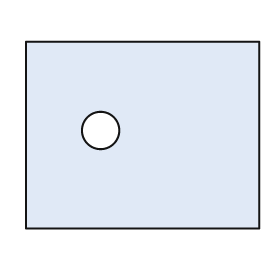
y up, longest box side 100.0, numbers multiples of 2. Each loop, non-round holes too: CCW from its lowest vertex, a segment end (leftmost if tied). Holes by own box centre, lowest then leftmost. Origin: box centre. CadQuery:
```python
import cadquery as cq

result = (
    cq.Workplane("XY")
    .moveTo(-50.0, -40.0)
    .lineTo(50.0, -40.0)
    .lineTo(50.0, 40.0)
    .lineTo(-50.0, 40.0)
    .close()
    .moveTo(-18.0, 2.0)
    .circle(8.0)
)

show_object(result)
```